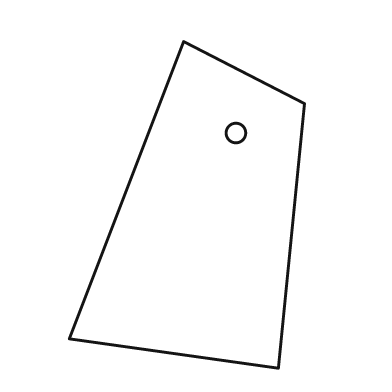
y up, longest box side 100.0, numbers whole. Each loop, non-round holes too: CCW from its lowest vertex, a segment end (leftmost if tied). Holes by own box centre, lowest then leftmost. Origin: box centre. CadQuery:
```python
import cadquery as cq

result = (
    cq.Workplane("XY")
    .moveTo(28.0, -50.0)
    .lineTo(36.0, 31.0)
    .lineTo(-1.0, 50.0)
    .lineTo(-36.0, -41.0)
    .close()
    .moveTo(15.0, 22.0)
    .circle(3.0)
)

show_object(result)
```